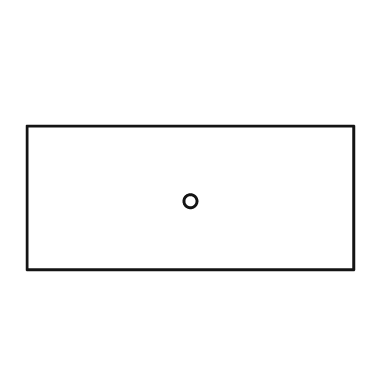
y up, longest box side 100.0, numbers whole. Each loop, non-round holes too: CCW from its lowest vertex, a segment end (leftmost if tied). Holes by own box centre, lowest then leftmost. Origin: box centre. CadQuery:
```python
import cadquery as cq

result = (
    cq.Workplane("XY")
    .moveTo(-50.0, -22.0)
    .lineTo(50.0, -22.0)
    .lineTo(50.0, 22.0)
    .lineTo(-50.0, 22.0)
    .close()
    .moveTo(0.0, -1.0)
    .circle(2.0)
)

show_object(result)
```